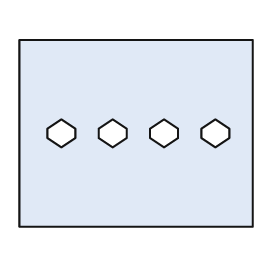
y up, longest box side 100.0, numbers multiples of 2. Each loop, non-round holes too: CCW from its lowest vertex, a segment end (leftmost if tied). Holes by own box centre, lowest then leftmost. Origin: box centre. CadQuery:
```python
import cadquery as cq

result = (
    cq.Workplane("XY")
    .moveTo(-50.0, -40.0)
    .lineTo(50.0, -40.0)
    .lineTo(50.0, 40.0)
    .lineTo(-50.0, 40.0)
    .close()
    .moveTo(-32.0, -6.0)
    .lineTo(-26.0, -2.0)
    .lineTo(-26.0, 2.0)
    .lineTo(-32.0, 6.0)
    .lineTo(-38.0, 2.0)
    .lineTo(-38.0, -2.0)
    .close()
    .moveTo(-10.0, -6.0)
    .lineTo(-4.0, -2.0)
    .lineTo(-4.0, 2.0)
    .lineTo(-10.0, 6.0)
    .lineTo(-16.0, 2.0)
    .lineTo(-16.0, -2.0)
    .close()
    .moveTo(12.0, -6.0)
    .lineTo(18.0, -2.0)
    .lineTo(18.0, 2.0)
    .lineTo(12.0, 6.0)
    .lineTo(6.0, 2.0)
    .lineTo(6.0, -2.0)
    .close()
    .moveTo(34.0, -6.0)
    .lineTo(40.0, -2.0)
    .lineTo(40.0, 2.0)
    .lineTo(34.0, 6.0)
    .lineTo(28.0, 2.0)
    .lineTo(28.0, -2.0)
    .close()
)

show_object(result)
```